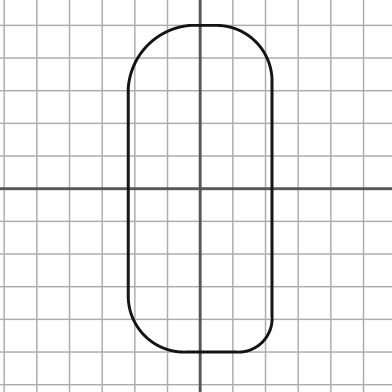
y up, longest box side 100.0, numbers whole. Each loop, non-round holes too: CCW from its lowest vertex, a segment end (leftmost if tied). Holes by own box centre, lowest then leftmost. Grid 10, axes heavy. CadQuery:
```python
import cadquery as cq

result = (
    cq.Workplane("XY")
    .moveTo(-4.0, -50.0)
    .lineTo(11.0, -50.0)
    .threePointArc((19.0, -47.0), (22.0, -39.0))
    .lineTo(22.0, 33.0)
    .threePointArc((17.0, 45.0), (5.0, 50.0))
    .lineTo(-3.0, 50.0)
    .threePointArc((-16.0, 44.0), (-22.0, 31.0))
    .lineTo(-22.0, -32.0)
    .threePointArc((-17.0, -45.0), (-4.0, -50.0))
    .close()
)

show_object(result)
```